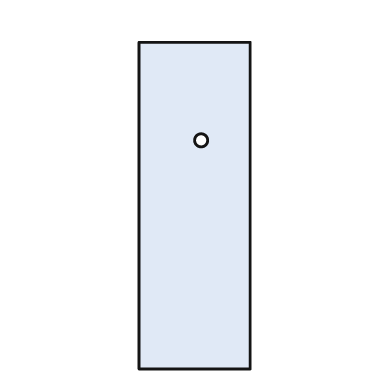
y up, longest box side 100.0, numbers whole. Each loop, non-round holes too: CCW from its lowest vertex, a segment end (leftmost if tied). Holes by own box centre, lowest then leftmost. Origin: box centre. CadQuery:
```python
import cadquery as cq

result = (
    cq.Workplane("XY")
    .moveTo(-17.0, -50.0)
    .lineTo(17.0, -50.0)
    .lineTo(17.0, 50.0)
    .lineTo(-17.0, 50.0)
    .close()
    .moveTo(2.0, 20.0)
    .circle(2.0)
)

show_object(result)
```